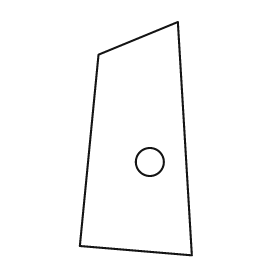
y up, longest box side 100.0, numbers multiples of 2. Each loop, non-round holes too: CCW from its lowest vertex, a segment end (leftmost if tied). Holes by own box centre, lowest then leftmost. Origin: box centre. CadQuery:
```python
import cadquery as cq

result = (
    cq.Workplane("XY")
    .moveTo(24.0, -50.0)
    .lineTo(18.0, 50.0)
    .lineTo(-16.0, 36.0)
    .lineTo(-24.0, -46.0)
    .close()
    .moveTo(6.0, -10.0)
    .circle(6.0)
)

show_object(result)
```